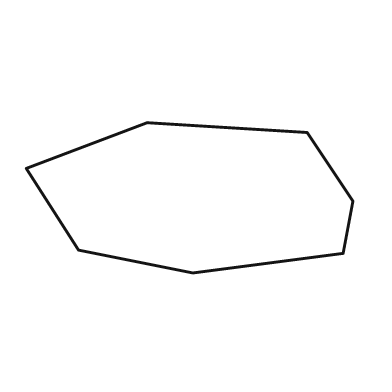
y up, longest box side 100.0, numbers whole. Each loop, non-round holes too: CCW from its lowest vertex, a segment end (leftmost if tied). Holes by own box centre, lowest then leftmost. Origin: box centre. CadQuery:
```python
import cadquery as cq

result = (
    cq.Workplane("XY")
    .moveTo(1.0, -23.0)
    .lineTo(47.0, -17.0)
    .lineTo(50.0, -1.0)
    .lineTo(36.0, 20.0)
    .lineTo(-13.0, 23.0)
    .lineTo(-50.0, 9.0)
    .lineTo(-34.0, -16.0)
    .close()
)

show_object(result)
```